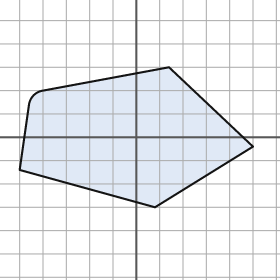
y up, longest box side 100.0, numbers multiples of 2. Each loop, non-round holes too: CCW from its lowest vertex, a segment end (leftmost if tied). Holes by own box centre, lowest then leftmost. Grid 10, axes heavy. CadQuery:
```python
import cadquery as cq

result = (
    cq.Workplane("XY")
    .moveTo(8.0, -30.0)
    .lineTo(50.0, -4.0)
    .lineTo(14.0, 30.0)
    .lineTo(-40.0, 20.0)
    .threePointArc((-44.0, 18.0), (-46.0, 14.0))
    .lineTo(-50.0, -14.0)
    .close()
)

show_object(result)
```